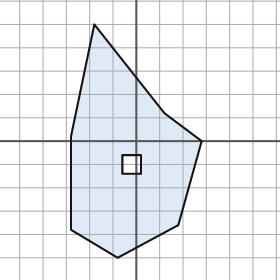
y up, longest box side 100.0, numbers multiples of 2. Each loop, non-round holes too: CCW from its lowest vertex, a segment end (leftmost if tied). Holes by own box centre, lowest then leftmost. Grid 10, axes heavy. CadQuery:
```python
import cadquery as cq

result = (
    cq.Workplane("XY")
    .moveTo(-8.0, -50.0)
    .lineTo(18.0, -36.0)
    .lineTo(28.0, 0.0)
    .lineTo(12.0, 12.0)
    .lineTo(-18.0, 50.0)
    .lineTo(-28.0, 2.0)
    .lineTo(-28.0, -38.0)
    .close()
    .moveTo(-6.0, -14.0)
    .lineTo(2.0, -14.0)
    .lineTo(2.0, -6.0)
    .lineTo(-6.0, -6.0)
    .close()
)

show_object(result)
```